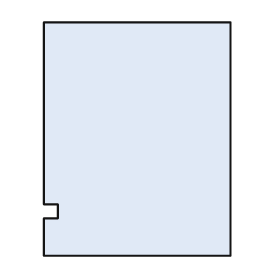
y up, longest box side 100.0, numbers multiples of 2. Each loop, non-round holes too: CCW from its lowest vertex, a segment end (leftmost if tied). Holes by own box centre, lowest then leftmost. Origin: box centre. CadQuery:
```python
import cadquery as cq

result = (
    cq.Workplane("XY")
    .moveTo(-40.0, -50.0)
    .lineTo(40.0, -50.0)
    .lineTo(40.0, 50.0)
    .lineTo(-40.0, 50.0)
    .lineTo(-40.0, -28.0)
    .lineTo(-34.0, -28.0)
    .lineTo(-34.0, -34.0)
    .lineTo(-40.0, -34.0)
    .close()
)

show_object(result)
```